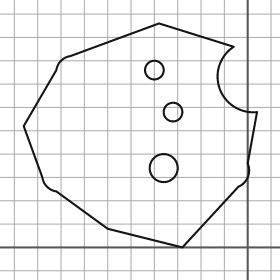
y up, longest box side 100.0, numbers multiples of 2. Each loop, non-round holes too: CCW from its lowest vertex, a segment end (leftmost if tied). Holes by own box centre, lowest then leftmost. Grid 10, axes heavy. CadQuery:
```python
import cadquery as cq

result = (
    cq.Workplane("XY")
    .moveTo(-28.0, 0.0)
    .lineTo(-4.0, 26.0)
    .threePointArc((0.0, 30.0), (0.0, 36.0))
    .lineTo(4.0, 58.0)
    .threePointArc((-12.0, 68.0), (-6.0, 86.0))
    .lineTo(-38.0, 96.0)
    .lineTo(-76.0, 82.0)
    .threePointArc((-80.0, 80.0), (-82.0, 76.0))
    .lineTo(-96.0, 52.0)
    .lineTo(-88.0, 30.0)
    .threePointArc((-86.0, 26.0), (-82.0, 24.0))
    .lineTo(-60.0, 8.0)
    .close()
    .moveTo(-36.0, 34.0)
    .circle(6.0)
    .moveTo(-32.0, 58.0)
    .circle(4.0)
    .moveTo(-40.0, 76.0)
    .circle(4.0)
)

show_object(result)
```